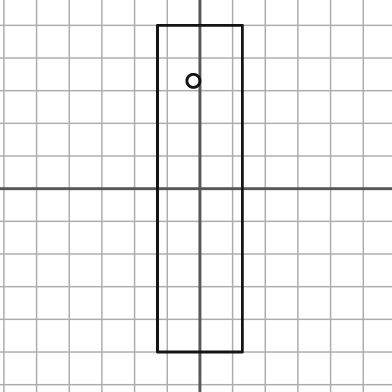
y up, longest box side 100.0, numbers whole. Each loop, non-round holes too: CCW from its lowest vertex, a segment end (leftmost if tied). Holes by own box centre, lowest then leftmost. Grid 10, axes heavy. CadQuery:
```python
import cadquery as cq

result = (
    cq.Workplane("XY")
    .moveTo(-13.0, -50.0)
    .lineTo(13.0, -50.0)
    .lineTo(13.0, 50.0)
    .lineTo(-13.0, 50.0)
    .close()
    .moveTo(-2.0, 33.0)
    .circle(2.0)
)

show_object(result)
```